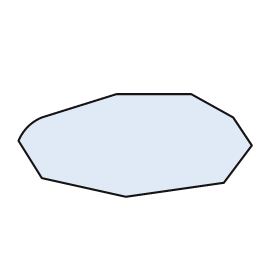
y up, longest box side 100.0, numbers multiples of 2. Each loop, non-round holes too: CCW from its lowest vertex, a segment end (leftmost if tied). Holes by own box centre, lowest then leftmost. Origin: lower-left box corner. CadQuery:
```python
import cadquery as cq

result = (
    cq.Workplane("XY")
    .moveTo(46.0, 0.0)
    .lineTo(88.0, 6.0)
    .lineTo(100.0, 22.0)
    .lineTo(92.0, 34.0)
    .lineTo(74.0, 44.0)
    .lineTo(42.0, 44.0)
    .lineTo(10.0, 34.0)
    .threePointArc((4.0, 30.0), (0.0, 24.0))
    .lineTo(10.0, 8.0)
    .close()
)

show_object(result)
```